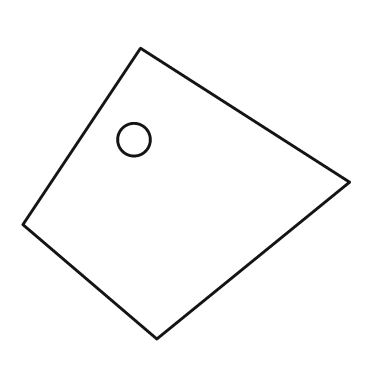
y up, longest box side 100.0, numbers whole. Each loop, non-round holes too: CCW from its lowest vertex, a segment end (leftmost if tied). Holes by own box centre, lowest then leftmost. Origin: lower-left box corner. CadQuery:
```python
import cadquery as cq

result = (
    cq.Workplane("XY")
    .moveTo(41.0, 0.0)
    .lineTo(100.0, 48.0)
    .lineTo(36.0, 89.0)
    .lineTo(0.0, 35.0)
    .close()
    .moveTo(34.0, 61.0)
    .circle(5.0)
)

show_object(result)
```